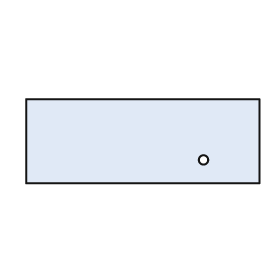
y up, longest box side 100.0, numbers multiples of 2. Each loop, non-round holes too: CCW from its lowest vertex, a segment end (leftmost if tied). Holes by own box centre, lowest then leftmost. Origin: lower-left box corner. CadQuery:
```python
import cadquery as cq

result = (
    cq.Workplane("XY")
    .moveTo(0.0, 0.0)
    .lineTo(100.0, 0.0)
    .lineTo(100.0, 36.0)
    .lineTo(0.0, 36.0)
    .close()
    .moveTo(76.0, 10.0)
    .circle(2.0)
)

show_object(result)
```